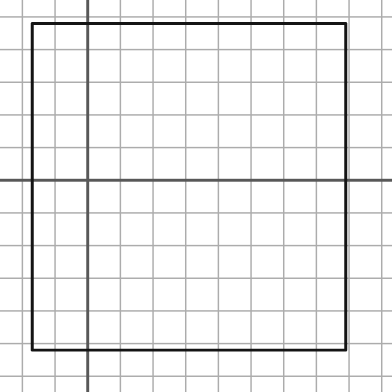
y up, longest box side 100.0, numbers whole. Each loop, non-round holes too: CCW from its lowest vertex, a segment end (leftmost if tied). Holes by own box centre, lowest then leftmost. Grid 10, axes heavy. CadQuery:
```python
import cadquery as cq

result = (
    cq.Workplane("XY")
    .moveTo(-17.0, -52.0)
    .lineTo(79.0, -52.0)
    .lineTo(79.0, 48.0)
    .lineTo(-17.0, 48.0)
    .close()
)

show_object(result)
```